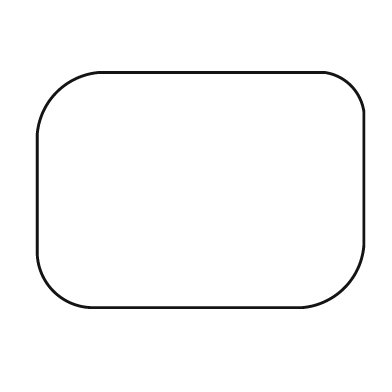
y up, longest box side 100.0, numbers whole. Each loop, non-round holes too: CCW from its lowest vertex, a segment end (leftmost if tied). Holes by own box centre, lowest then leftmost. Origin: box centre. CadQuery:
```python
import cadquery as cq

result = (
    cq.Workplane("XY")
    .moveTo(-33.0, -36.0)
    .lineTo(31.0, -36.0)
    .threePointArc((44.0, -30.0), (50.0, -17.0))
    .lineTo(50.0, 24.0)
    .threePointArc((46.0, 32.0), (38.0, 36.0))
    .lineTo(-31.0, 36.0)
    .threePointArc((-44.0, 30.0), (-50.0, 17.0))
    .lineTo(-50.0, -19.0)
    .threePointArc((-45.0, -31.0), (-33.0, -36.0))
    .close()
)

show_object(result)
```